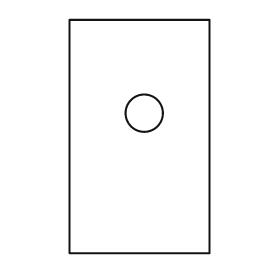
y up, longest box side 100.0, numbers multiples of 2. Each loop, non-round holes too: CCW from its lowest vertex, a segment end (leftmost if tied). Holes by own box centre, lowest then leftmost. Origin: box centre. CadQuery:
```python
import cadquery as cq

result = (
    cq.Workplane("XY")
    .moveTo(-30.0, -50.0)
    .lineTo(30.0, -50.0)
    .lineTo(30.0, 50.0)
    .lineTo(-30.0, 50.0)
    .close()
    .moveTo(2.0, 10.0)
    .circle(8.0)
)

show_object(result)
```